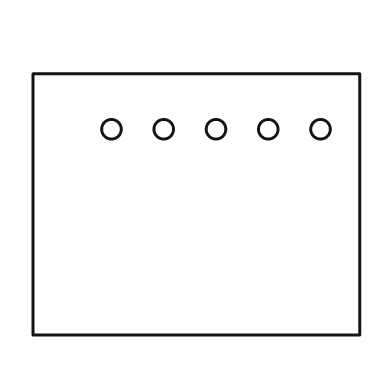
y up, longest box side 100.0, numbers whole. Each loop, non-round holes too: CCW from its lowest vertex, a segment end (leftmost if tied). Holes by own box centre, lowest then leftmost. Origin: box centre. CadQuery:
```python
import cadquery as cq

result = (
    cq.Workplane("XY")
    .moveTo(-50.0, -40.0)
    .lineTo(50.0, -40.0)
    .lineTo(50.0, 40.0)
    .lineTo(-50.0, 40.0)
    .close()
    .moveTo(-26.0, 23.0)
    .circle(3.0)
    .moveTo(-10.0, 23.0)
    .circle(3.0)
    .moveTo(6.0, 23.0)
    .circle(3.0)
    .moveTo(22.0, 23.0)
    .circle(3.0)
    .moveTo(38.0, 23.0)
    .circle(3.0)
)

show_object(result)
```